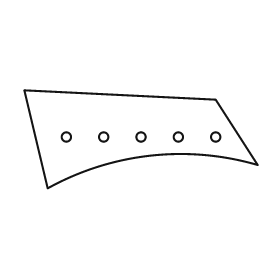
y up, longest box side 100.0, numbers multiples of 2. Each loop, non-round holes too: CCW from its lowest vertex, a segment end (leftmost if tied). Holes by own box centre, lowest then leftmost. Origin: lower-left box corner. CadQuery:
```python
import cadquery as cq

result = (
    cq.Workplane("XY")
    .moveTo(10.0, 0.0)
    .threePointArc((54.0, 14.0), (100.0, 10.0))
    .lineTo(82.0, 38.0)
    .lineTo(0.0, 42.0)
    .close()
    .moveTo(18.0, 22.0)
    .circle(2.0)
    .moveTo(34.0, 22.0)
    .circle(2.0)
    .moveTo(50.0, 22.0)
    .circle(2.0)
    .moveTo(66.0, 22.0)
    .circle(2.0)
    .moveTo(82.0, 22.0)
    .circle(2.0)
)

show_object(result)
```